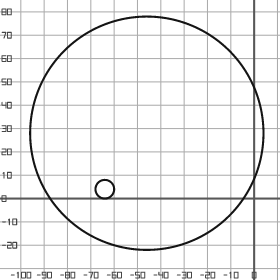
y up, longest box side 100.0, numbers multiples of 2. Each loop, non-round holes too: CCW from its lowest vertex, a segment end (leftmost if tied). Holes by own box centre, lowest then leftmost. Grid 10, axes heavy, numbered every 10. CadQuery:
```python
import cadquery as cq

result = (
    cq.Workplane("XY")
    .moveTo(-46.0, 28.0)
    .circle(50.0)
    .moveTo(-64.0, 4.0)
    .circle(4.0)
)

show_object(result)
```